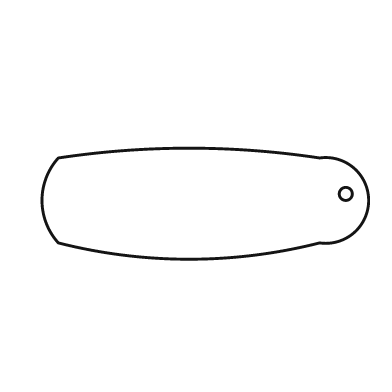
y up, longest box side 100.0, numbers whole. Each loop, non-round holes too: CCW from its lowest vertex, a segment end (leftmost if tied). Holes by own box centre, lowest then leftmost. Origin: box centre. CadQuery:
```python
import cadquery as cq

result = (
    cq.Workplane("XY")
    .moveTo(-45.0, -12.0)
    .threePointArc((-5.0, -17.0), (35.0, -12.0))
    .threePointArc((50.0, 1.0), (35.0, 14.0))
    .threePointArc((-5.0, 17.0), (-45.0, 14.0))
    .threePointArc((-50.0, 1.0), (-45.0, -12.0))
    .close()
    .moveTo(43.0, 3.0)
    .circle(2.0)
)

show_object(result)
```